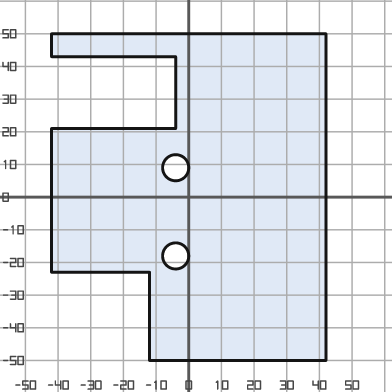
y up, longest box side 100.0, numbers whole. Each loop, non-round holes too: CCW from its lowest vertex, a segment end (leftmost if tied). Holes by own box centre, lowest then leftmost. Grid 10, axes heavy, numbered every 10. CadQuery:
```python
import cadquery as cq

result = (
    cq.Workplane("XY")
    .moveTo(-12.0, -50.0)
    .lineTo(42.0, -50.0)
    .lineTo(42.0, 50.0)
    .lineTo(-42.0, 50.0)
    .lineTo(-42.0, 43.0)
    .lineTo(-4.0, 43.0)
    .lineTo(-4.0, 21.0)
    .lineTo(-42.0, 21.0)
    .lineTo(-42.0, -23.0)
    .lineTo(-12.0, -23.0)
    .close()
    .moveTo(-4.0, -18.0)
    .circle(4.0)
    .moveTo(-4.0, 9.0)
    .circle(4.0)
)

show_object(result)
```